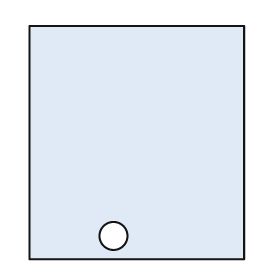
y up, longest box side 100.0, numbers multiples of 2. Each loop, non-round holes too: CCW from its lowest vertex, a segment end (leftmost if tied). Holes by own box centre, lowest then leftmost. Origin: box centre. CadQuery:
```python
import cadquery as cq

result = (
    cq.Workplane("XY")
    .moveTo(-46.0, -50.0)
    .lineTo(46.0, -50.0)
    .lineTo(46.0, 50.0)
    .lineTo(-46.0, 50.0)
    .close()
    .moveTo(-10.0, -40.0)
    .circle(6.0)
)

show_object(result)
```